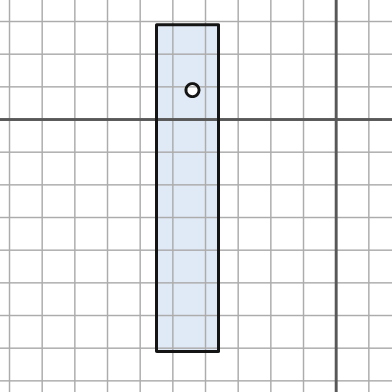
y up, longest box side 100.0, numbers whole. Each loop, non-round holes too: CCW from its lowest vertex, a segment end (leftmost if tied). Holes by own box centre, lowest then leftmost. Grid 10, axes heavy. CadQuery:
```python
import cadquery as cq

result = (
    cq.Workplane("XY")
    .moveTo(-55.0, -71.0)
    .lineTo(-36.0, -71.0)
    .lineTo(-36.0, 29.0)
    .lineTo(-55.0, 29.0)
    .close()
    .moveTo(-44.0, 9.0)
    .circle(2.0)
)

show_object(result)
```